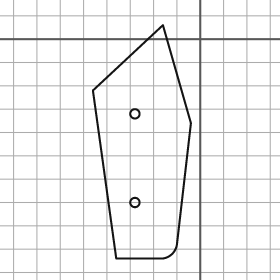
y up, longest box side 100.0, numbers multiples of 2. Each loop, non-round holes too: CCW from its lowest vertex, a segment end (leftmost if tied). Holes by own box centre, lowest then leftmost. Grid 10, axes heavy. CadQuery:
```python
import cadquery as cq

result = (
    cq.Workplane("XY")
    .moveTo(-36.0, -94.0)
    .lineTo(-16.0, -94.0)
    .threePointArc((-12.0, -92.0), (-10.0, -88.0))
    .lineTo(-4.0, -36.0)
    .lineTo(-16.0, 6.0)
    .lineTo(-46.0, -22.0)
    .close()
    .moveTo(-28.0, -70.0)
    .circle(2.0)
    .moveTo(-28.0, -32.0)
    .circle(2.0)
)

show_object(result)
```